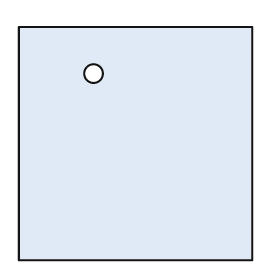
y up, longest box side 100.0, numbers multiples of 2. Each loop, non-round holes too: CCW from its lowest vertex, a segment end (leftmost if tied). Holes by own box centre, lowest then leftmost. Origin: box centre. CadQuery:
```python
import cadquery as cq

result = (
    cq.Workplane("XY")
    .moveTo(-50.0, -50.0)
    .lineTo(50.0, -50.0)
    .lineTo(50.0, 50.0)
    .lineTo(-50.0, 50.0)
    .close()
    .moveTo(-18.0, 30.0)
    .circle(4.0)
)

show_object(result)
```